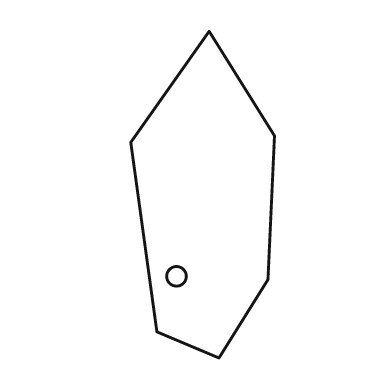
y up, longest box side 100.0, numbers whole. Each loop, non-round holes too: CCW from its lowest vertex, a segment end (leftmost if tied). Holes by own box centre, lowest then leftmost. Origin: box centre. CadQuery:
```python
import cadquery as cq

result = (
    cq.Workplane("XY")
    .moveTo(5.0, -50.0)
    .lineTo(20.0, -26.0)
    .lineTo(22.0, 18.0)
    .lineTo(2.0, 50.0)
    .lineTo(-22.0, 16.0)
    .lineTo(-14.0, -42.0)
    .close()
    .moveTo(-8.0, -25.0)
    .circle(3.0)
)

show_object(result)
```